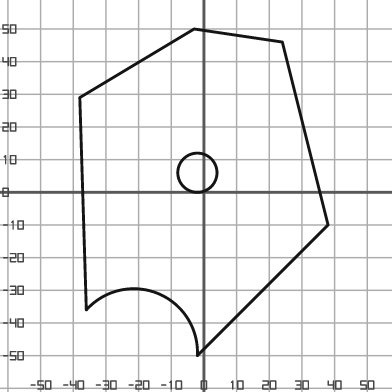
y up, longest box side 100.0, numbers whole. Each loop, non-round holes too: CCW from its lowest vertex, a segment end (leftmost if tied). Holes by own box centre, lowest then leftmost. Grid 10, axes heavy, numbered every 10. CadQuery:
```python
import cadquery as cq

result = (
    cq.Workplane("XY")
    .moveTo(-2.0, -50.0)
    .lineTo(38.0, -10.0)
    .lineTo(24.0, 46.0)
    .lineTo(-3.0, 50.0)
    .lineTo(-38.0, 29.0)
    .lineTo(-36.0, -36.0)
    .threePointArc((-14.0, -31.0), (-2.0, -50.0))
    .close()
    .moveTo(-2.0, 6.0)
    .circle(6.0)
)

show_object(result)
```